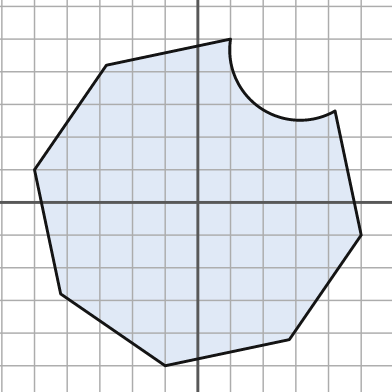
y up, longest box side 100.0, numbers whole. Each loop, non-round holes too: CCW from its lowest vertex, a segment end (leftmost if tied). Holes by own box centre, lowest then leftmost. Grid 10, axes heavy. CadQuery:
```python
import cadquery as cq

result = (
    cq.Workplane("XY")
    .moveTo(-10.0, -50.0)
    .lineTo(28.0, -42.0)
    .lineTo(50.0, -10.0)
    .lineTo(42.0, 28.0)
    .threePointArc((19.0, 29.0), (10.0, 50.0))
    .lineTo(-28.0, 42.0)
    .lineTo(-50.0, 10.0)
    .lineTo(-42.0, -28.0)
    .close()
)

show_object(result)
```